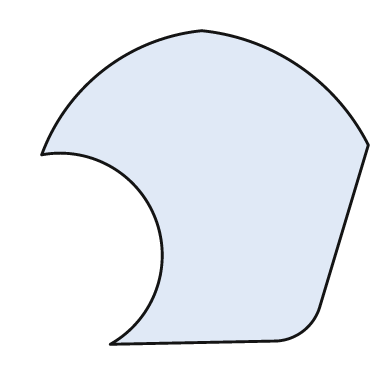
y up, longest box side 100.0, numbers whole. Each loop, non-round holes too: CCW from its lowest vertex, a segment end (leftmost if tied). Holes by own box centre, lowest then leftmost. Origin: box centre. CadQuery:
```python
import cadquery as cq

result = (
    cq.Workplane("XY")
    .moveTo(-29.0, -48.0)
    .lineTo(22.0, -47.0)
    .threePointArc((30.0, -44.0), (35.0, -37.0))
    .lineTo(50.0, 13.0)
    .threePointArc((29.0, 37.0), (-1.0, 48.0))
    .threePointArc((-31.0, 36.0), (-50.0, 10.0))
    .threePointArc((-15.0, -10.0), (-29.0, -48.0))
    .close()
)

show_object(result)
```